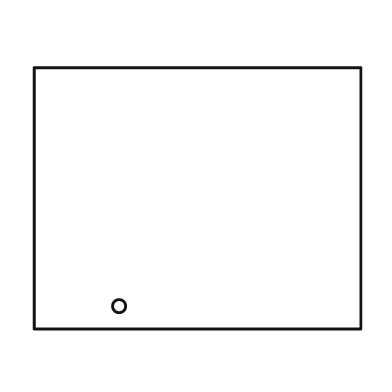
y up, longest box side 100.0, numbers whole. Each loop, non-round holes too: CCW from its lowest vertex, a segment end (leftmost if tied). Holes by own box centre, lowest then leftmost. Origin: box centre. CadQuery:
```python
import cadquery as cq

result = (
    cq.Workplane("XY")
    .moveTo(-50.0, -40.0)
    .lineTo(50.0, -40.0)
    .lineTo(50.0, 40.0)
    .lineTo(-50.0, 40.0)
    .close()
    .moveTo(-24.0, -33.0)
    .circle(2.0)
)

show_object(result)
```